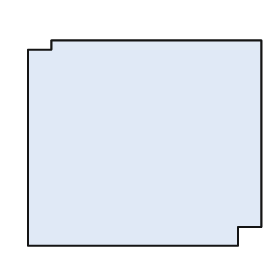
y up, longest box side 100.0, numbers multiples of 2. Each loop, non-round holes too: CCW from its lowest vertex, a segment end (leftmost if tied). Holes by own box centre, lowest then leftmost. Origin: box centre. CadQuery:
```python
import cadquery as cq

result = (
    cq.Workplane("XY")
    .moveTo(-50.0, -44.0)
    .lineTo(40.0, -44.0)
    .lineTo(40.0, -36.0)
    .lineTo(50.0, -36.0)
    .lineTo(50.0, 44.0)
    .lineTo(-40.0, 44.0)
    .lineTo(-40.0, 40.0)
    .lineTo(-50.0, 40.0)
    .close()
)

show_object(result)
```